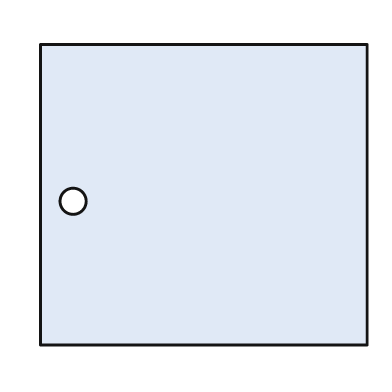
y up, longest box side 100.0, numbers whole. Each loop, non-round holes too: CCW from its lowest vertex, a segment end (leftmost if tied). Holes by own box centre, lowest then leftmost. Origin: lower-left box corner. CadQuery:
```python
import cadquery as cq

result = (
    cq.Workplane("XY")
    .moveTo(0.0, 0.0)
    .lineTo(100.0, 0.0)
    .lineTo(100.0, 92.0)
    .lineTo(0.0, 92.0)
    .close()
    .moveTo(10.0, 44.0)
    .circle(4.0)
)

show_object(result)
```